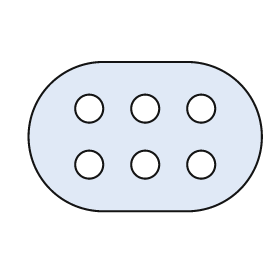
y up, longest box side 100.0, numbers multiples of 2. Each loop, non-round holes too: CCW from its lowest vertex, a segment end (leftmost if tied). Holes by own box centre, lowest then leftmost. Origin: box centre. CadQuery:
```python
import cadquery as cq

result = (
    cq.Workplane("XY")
    .moveTo(-18.0, -32.0)
    .lineTo(18.0, -32.0)
    .threePointArc((50.0, 0.0), (18.0, 32.0))
    .lineTo(-18.0, 32.0)
    .threePointArc((-50.0, 0.0), (-18.0, -32.0))
    .close()
    .moveTo(-24.0, -12.0)
    .circle(6.0)
    .moveTo(0.0, -12.0)
    .circle(6.0)
    .moveTo(24.0, -12.0)
    .circle(6.0)
    .moveTo(-24.0, 12.0)
    .circle(6.0)
    .moveTo(0.0, 12.0)
    .circle(6.0)
    .moveTo(24.0, 12.0)
    .circle(6.0)
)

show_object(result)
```